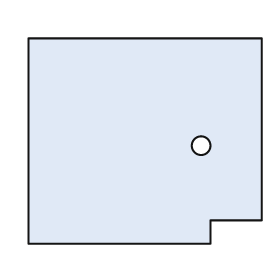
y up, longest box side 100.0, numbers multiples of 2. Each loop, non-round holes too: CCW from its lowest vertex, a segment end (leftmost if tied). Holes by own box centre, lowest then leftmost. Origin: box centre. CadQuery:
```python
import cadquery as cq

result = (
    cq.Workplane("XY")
    .moveTo(-50.0, -44.0)
    .lineTo(28.0, -44.0)
    .lineTo(28.0, -34.0)
    .lineTo(50.0, -34.0)
    .lineTo(50.0, 44.0)
    .lineTo(-50.0, 44.0)
    .close()
    .moveTo(24.0, -2.0)
    .circle(4.0)
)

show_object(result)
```